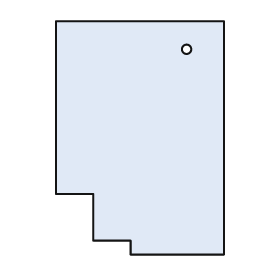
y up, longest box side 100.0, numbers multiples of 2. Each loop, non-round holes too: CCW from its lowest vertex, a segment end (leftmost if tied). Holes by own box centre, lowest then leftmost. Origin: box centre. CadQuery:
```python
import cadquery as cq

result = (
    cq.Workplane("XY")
    .moveTo(-4.0, -50.0)
    .lineTo(36.0, -50.0)
    .lineTo(36.0, 50.0)
    .lineTo(-36.0, 50.0)
    .lineTo(-36.0, -24.0)
    .lineTo(-20.0, -24.0)
    .lineTo(-20.0, -44.0)
    .lineTo(-4.0, -44.0)
    .close()
    .moveTo(20.0, 38.0)
    .circle(2.0)
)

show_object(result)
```